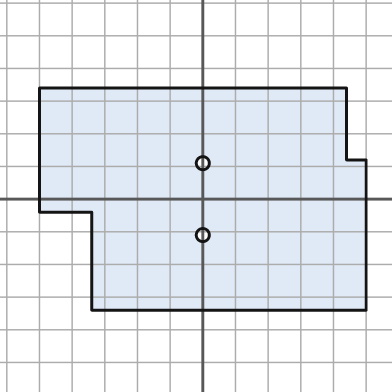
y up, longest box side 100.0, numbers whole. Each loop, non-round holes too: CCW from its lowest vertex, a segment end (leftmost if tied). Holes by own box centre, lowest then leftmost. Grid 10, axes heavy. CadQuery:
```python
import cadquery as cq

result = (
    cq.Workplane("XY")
    .moveTo(-34.0, -34.0)
    .lineTo(50.0, -34.0)
    .lineTo(50.0, 12.0)
    .lineTo(44.0, 12.0)
    .lineTo(44.0, 34.0)
    .lineTo(-50.0, 34.0)
    .lineTo(-50.0, -4.0)
    .lineTo(-34.0, -4.0)
    .close()
    .moveTo(0.0, -11.0)
    .circle(2.0)
    .moveTo(0.0, 11.0)
    .circle(2.0)
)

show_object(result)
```